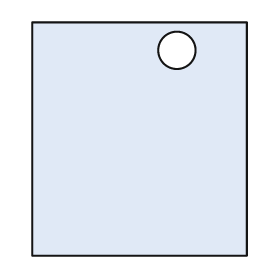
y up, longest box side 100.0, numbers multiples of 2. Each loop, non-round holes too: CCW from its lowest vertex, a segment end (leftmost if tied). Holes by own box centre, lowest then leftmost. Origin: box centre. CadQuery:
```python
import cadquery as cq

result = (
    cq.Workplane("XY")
    .moveTo(-46.0, -50.0)
    .lineTo(46.0, -50.0)
    .lineTo(46.0, 50.0)
    .lineTo(-46.0, 50.0)
    .close()
    .moveTo(16.0, 38.0)
    .circle(8.0)
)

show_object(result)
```